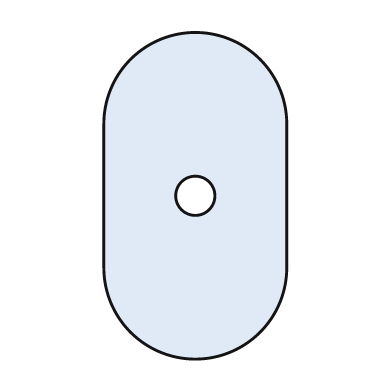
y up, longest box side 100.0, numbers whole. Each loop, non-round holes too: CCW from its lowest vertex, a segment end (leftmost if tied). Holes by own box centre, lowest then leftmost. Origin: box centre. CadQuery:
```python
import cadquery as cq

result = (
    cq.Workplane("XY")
    .moveTo(-28.0, -22.0)
    .threePointArc((0.0, -50.0), (28.0, -22.0))
    .lineTo(28.0, 22.0)
    .threePointArc((0.0, 50.0), (-28.0, 22.0))
    .close()
    .moveTo(0.0, 0.0)
    .circle(6.0)
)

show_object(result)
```